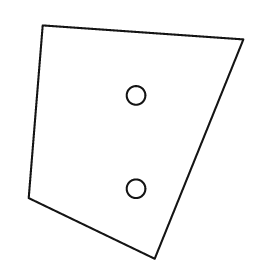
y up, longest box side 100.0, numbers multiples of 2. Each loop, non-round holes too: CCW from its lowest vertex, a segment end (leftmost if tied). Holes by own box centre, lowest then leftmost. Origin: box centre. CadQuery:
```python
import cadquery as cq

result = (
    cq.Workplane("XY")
    .moveTo(8.0, -50.0)
    .lineTo(46.0, 44.0)
    .lineTo(-40.0, 50.0)
    .lineTo(-46.0, -24.0)
    .close()
    .moveTo(0.0, -20.0)
    .circle(4.0)
    .moveTo(0.0, 20.0)
    .circle(4.0)
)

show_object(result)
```